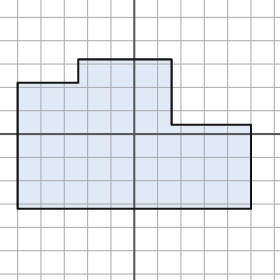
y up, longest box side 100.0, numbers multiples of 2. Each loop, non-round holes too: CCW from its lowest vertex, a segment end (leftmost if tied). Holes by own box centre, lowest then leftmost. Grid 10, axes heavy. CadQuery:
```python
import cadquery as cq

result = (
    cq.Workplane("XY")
    .moveTo(-50.0, -32.0)
    .lineTo(50.0, -32.0)
    .lineTo(50.0, 4.0)
    .lineTo(16.0, 4.0)
    .lineTo(16.0, 32.0)
    .lineTo(-24.0, 32.0)
    .lineTo(-24.0, 22.0)
    .lineTo(-50.0, 22.0)
    .close()
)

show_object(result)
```